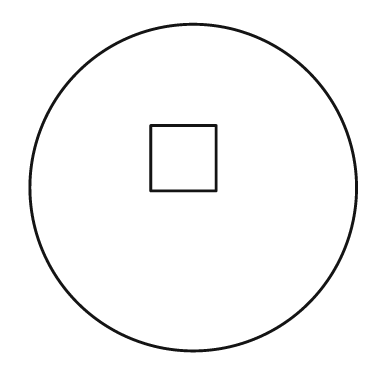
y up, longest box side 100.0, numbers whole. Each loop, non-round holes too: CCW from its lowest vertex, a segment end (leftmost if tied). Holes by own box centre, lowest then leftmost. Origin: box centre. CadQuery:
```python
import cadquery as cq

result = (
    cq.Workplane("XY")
    .moveTo(0.0, 0.0)
    .circle(50.0)
    .moveTo(-13.0, -1.0)
    .lineTo(7.0, -1.0)
    .lineTo(7.0, 19.0)
    .lineTo(-13.0, 19.0)
    .close()
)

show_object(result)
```